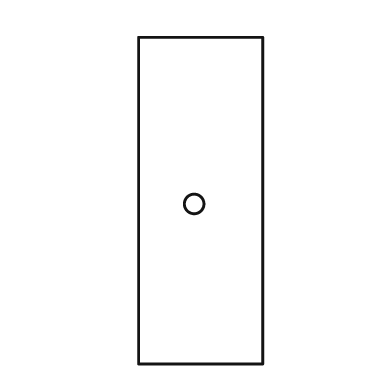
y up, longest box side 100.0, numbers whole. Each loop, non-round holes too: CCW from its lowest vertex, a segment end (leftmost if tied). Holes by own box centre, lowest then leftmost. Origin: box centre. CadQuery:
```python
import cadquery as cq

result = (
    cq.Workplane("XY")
    .moveTo(-19.0, -50.0)
    .lineTo(19.0, -50.0)
    .lineTo(19.0, 50.0)
    .lineTo(-19.0, 50.0)
    .close()
    .moveTo(-2.0, -1.0)
    .circle(3.0)
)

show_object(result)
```